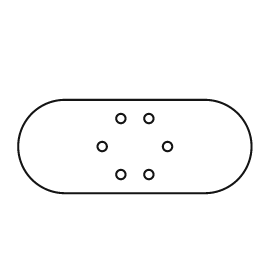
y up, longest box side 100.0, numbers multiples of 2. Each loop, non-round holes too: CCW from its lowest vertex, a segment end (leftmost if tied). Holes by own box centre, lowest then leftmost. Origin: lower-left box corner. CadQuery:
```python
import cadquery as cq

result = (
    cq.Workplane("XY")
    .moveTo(20.0, 0.0)
    .lineTo(80.0, 0.0)
    .threePointArc((100.0, 20.0), (80.0, 40.0))
    .lineTo(20.0, 40.0)
    .threePointArc((0.0, 20.0), (20.0, 0.0))
    .close()
    .moveTo(44.0, 8.0)
    .circle(2.0)
    .moveTo(56.0, 8.0)
    .circle(2.0)
    .moveTo(36.0, 20.0)
    .circle(2.0)
    .moveTo(64.0, 20.0)
    .circle(2.0)
    .moveTo(44.0, 32.0)
    .circle(2.0)
    .moveTo(56.0, 32.0)
    .circle(2.0)
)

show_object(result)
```